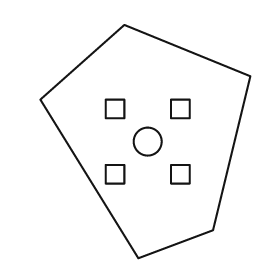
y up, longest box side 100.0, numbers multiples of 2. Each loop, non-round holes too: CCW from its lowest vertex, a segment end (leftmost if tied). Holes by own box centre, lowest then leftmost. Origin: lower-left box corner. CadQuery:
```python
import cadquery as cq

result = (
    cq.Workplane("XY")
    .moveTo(42.0, 0.0)
    .lineTo(74.0, 12.0)
    .lineTo(90.0, 78.0)
    .lineTo(36.0, 100.0)
    .lineTo(0.0, 68.0)
    .close()
    .moveTo(28.0, 32.0)
    .lineTo(36.0, 32.0)
    .lineTo(36.0, 40.0)
    .lineTo(28.0, 40.0)
    .close()
    .moveTo(56.0, 32.0)
    .lineTo(64.0, 32.0)
    .lineTo(64.0, 40.0)
    .lineTo(56.0, 40.0)
    .close()
    .moveTo(46.0, 50.0)
    .circle(6.0)
    .moveTo(28.0, 60.0)
    .lineTo(36.0, 60.0)
    .lineTo(36.0, 68.0)
    .lineTo(28.0, 68.0)
    .close()
    .moveTo(56.0, 60.0)
    .lineTo(64.0, 60.0)
    .lineTo(64.0, 68.0)
    .lineTo(56.0, 68.0)
    .close()
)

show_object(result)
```